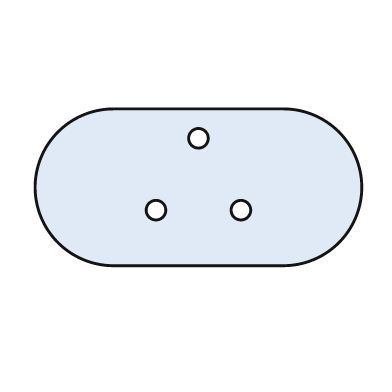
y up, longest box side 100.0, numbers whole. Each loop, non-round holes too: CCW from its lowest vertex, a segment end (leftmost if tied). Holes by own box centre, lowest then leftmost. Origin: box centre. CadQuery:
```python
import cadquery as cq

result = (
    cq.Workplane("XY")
    .moveTo(-26.0, -24.0)
    .lineTo(26.0, -24.0)
    .threePointArc((50.0, 0.0), (26.0, 24.0))
    .lineTo(-26.0, 24.0)
    .threePointArc((-50.0, 0.0), (-26.0, -24.0))
    .close()
    .moveTo(-13.0, -7.0)
    .circle(3.0)
    .moveTo(13.0, -7.0)
    .circle(3.0)
    .moveTo(0.0, 15.0)
    .circle(3.0)
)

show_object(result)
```